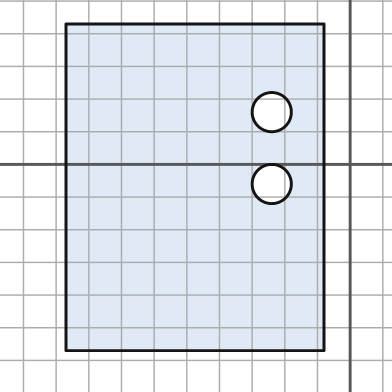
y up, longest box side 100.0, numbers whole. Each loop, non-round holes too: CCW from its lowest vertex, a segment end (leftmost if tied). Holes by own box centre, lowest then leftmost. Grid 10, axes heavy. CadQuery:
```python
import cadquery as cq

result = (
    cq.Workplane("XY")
    .moveTo(-87.0, -57.0)
    .lineTo(-8.0, -57.0)
    .lineTo(-8.0, 43.0)
    .lineTo(-87.0, 43.0)
    .close()
    .moveTo(-24.0, -6.0)
    .circle(6.0)
    .moveTo(-24.0, 16.0)
    .circle(6.0)
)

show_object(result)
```